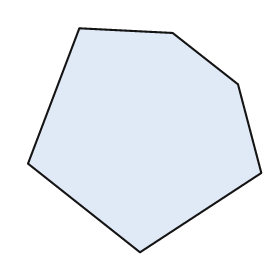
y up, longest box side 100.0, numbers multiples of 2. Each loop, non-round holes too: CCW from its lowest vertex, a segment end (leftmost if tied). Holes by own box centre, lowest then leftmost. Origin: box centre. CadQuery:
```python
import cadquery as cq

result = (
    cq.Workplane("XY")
    .moveTo(-2.0, -48.0)
    .lineTo(50.0, -14.0)
    .lineTo(40.0, 24.0)
    .lineTo(12.0, 46.0)
    .lineTo(-28.0, 48.0)
    .lineTo(-50.0, -10.0)
    .close()
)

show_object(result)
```